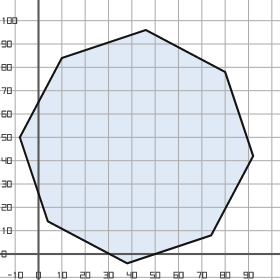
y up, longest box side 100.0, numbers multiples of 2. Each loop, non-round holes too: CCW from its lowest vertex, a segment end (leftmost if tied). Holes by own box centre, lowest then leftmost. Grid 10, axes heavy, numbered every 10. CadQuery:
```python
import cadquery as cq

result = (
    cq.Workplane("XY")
    .moveTo(38.0, -4.0)
    .lineTo(74.0, 8.0)
    .lineTo(92.0, 42.0)
    .lineTo(80.0, 78.0)
    .lineTo(46.0, 96.0)
    .lineTo(10.0, 84.0)
    .lineTo(-8.0, 50.0)
    .lineTo(4.0, 14.0)
    .close()
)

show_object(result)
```